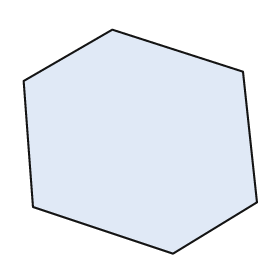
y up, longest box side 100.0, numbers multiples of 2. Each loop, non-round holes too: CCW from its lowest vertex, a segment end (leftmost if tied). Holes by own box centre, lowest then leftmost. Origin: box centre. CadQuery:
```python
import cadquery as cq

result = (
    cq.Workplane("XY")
    .moveTo(14.0, -48.0)
    .lineTo(50.0, -26.0)
    .lineTo(44.0, 30.0)
    .lineTo(-12.0, 48.0)
    .lineTo(-50.0, 26.0)
    .lineTo(-46.0, -28.0)
    .close()
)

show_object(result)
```